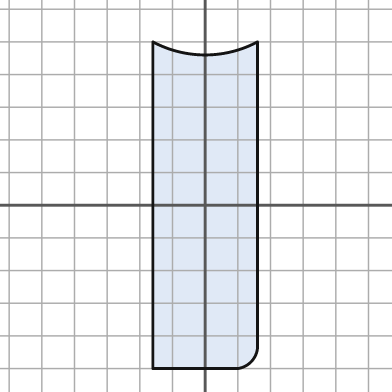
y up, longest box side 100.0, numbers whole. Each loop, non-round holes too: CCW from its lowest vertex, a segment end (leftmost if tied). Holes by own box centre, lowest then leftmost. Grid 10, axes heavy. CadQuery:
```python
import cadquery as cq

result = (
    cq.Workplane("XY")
    .moveTo(-16.0, -50.0)
    .lineTo(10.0, -50.0)
    .threePointArc((14.0, -48.0), (16.0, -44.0))
    .lineTo(16.0, 50.0)
    .threePointArc((0.0, 46.0), (-16.0, 50.0))
    .close()
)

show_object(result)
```